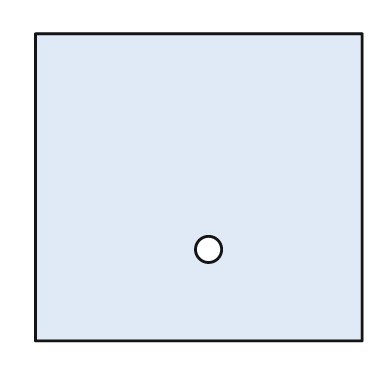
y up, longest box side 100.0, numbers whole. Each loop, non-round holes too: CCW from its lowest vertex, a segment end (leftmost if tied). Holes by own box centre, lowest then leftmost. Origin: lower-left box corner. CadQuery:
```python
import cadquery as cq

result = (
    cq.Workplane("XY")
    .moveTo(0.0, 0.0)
    .lineTo(100.0, 0.0)
    .lineTo(100.0, 94.0)
    .lineTo(0.0, 94.0)
    .close()
    .moveTo(53.0, 28.0)
    .circle(4.0)
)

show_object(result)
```